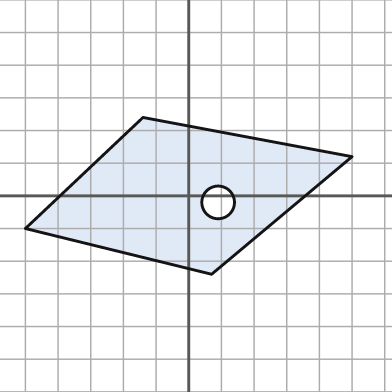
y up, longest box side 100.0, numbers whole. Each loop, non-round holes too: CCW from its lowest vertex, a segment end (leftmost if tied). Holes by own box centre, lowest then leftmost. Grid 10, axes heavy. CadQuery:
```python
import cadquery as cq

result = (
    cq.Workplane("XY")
    .moveTo(7.0, -24.0)
    .lineTo(50.0, 12.0)
    .lineTo(-14.0, 24.0)
    .lineTo(-50.0, -10.0)
    .close()
    .moveTo(9.0, -2.0)
    .circle(5.0)
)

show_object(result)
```